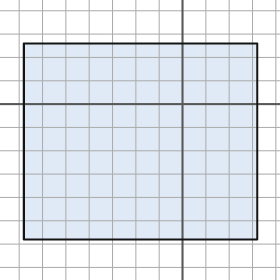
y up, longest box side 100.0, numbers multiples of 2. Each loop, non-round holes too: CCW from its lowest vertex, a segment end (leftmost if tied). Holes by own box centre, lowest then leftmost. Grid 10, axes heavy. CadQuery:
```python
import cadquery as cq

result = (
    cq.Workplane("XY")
    .moveTo(-68.0, -58.0)
    .lineTo(32.0, -58.0)
    .lineTo(32.0, 26.0)
    .lineTo(-68.0, 26.0)
    .close()
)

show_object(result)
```